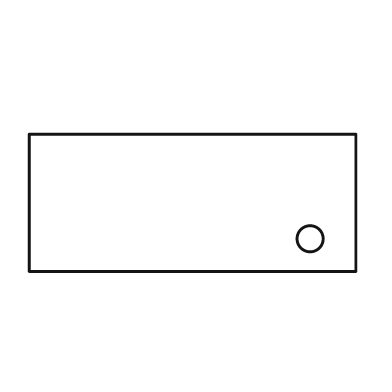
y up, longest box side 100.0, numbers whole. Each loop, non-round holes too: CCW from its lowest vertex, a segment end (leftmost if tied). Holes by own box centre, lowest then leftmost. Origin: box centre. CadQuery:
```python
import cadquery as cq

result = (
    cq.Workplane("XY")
    .moveTo(-50.0, -21.0)
    .lineTo(50.0, -21.0)
    .lineTo(50.0, 21.0)
    .lineTo(-50.0, 21.0)
    .close()
    .moveTo(36.0, -11.0)
    .circle(4.0)
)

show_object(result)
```